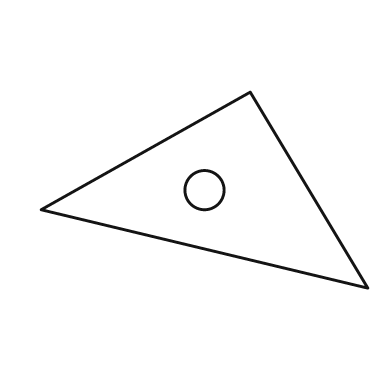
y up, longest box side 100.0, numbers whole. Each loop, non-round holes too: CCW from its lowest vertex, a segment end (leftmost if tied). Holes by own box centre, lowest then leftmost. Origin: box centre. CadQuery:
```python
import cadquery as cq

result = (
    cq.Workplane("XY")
    .moveTo(50.0, -30.0)
    .lineTo(14.0, 30.0)
    .lineTo(-50.0, -6.0)
    .close()
    .moveTo(0.0, 0.0)
    .circle(6.0)
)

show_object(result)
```